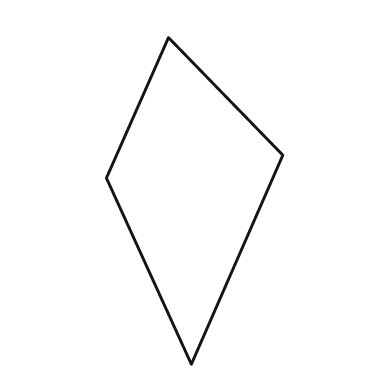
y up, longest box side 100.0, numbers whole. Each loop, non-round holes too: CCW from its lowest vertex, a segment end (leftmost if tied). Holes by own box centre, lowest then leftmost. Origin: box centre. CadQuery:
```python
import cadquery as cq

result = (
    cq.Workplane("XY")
    .moveTo(-1.0, -50.0)
    .lineTo(27.0, 14.0)
    .lineTo(-8.0, 50.0)
    .lineTo(-27.0, 7.0)
    .close()
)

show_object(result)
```